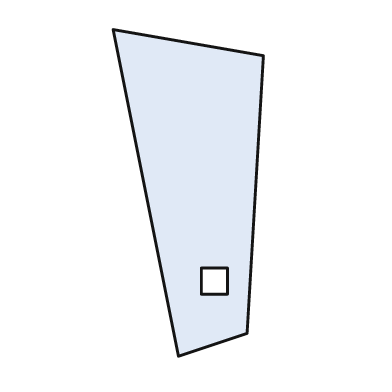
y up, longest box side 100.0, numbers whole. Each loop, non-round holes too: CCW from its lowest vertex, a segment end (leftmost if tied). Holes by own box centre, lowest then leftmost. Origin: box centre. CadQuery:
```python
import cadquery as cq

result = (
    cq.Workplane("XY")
    .moveTo(-3.0, -50.0)
    .lineTo(18.0, -43.0)
    .lineTo(23.0, 42.0)
    .lineTo(-23.0, 50.0)
    .close()
    .moveTo(4.0, -31.0)
    .lineTo(12.0, -31.0)
    .lineTo(12.0, -23.0)
    .lineTo(4.0, -23.0)
    .close()
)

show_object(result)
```